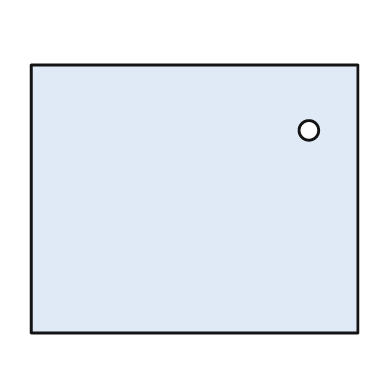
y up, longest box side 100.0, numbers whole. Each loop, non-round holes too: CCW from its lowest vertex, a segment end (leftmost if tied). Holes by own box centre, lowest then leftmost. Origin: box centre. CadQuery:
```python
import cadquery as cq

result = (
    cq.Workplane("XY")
    .moveTo(-50.0, -41.0)
    .lineTo(50.0, -41.0)
    .lineTo(50.0, 41.0)
    .lineTo(-50.0, 41.0)
    .close()
    .moveTo(35.0, 21.0)
    .circle(3.0)
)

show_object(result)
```